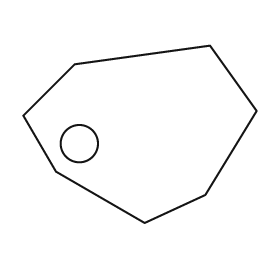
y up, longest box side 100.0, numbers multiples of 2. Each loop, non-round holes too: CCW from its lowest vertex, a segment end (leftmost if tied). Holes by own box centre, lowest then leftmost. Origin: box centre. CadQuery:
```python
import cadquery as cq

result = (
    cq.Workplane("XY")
    .moveTo(2.0, -38.0)
    .lineTo(28.0, -26.0)
    .lineTo(50.0, 10.0)
    .lineTo(30.0, 38.0)
    .lineTo(-28.0, 30.0)
    .lineTo(-50.0, 8.0)
    .lineTo(-36.0, -16.0)
    .close()
    .moveTo(-26.0, -4.0)
    .circle(8.0)
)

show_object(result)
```